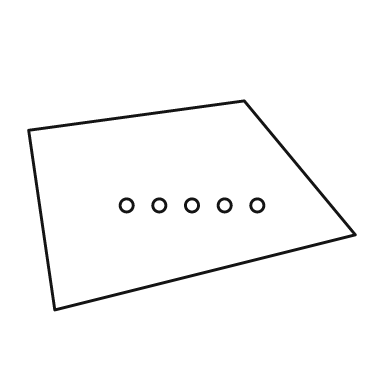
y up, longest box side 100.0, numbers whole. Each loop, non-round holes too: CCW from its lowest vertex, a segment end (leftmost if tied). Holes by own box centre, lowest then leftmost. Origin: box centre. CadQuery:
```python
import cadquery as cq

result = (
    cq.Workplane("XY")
    .moveTo(-42.0, -32.0)
    .lineTo(50.0, -9.0)
    .lineTo(16.0, 32.0)
    .lineTo(-50.0, 23.0)
    .close()
    .moveTo(-20.0, 0.0)
    .circle(2.0)
    .moveTo(-10.0, 0.0)
    .circle(2.0)
    .moveTo(0.0, 0.0)
    .circle(2.0)
    .moveTo(10.0, 0.0)
    .circle(2.0)
    .moveTo(20.0, 0.0)
    .circle(2.0)
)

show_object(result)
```